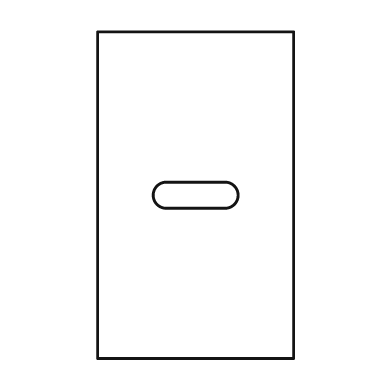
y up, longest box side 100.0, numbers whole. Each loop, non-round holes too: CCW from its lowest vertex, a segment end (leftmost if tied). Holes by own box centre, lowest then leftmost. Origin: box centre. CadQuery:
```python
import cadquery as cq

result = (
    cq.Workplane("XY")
    .moveTo(-30.0, -50.0)
    .lineTo(30.0, -50.0)
    .lineTo(30.0, 50.0)
    .lineTo(-30.0, 50.0)
    .close()
    .moveTo(-9.0, -4.0)
    .lineTo(9.0, -4.0)
    .threePointArc((13.0, 0.0), (9.0, 4.0))
    .lineTo(-9.0, 4.0)
    .threePointArc((-13.0, 0.0), (-9.0, -4.0))
    .close()
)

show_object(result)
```